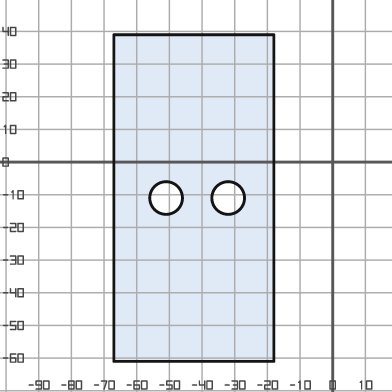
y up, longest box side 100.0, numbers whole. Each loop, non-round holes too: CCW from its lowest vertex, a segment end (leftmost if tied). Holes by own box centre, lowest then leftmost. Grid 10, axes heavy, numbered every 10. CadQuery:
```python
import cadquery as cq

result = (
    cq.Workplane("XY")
    .moveTo(-67.0, -61.0)
    .lineTo(-18.0, -61.0)
    .lineTo(-18.0, 39.0)
    .lineTo(-67.0, 39.0)
    .close()
    .moveTo(-51.0, -11.0)
    .circle(5.0)
    .moveTo(-32.0, -11.0)
    .circle(5.0)
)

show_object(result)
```